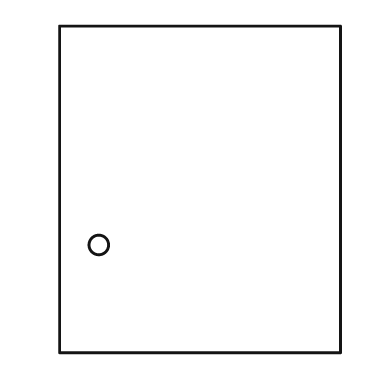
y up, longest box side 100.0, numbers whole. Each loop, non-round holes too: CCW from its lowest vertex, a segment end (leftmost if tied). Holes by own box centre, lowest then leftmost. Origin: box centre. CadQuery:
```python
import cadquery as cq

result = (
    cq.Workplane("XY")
    .moveTo(-43.0, -50.0)
    .lineTo(43.0, -50.0)
    .lineTo(43.0, 50.0)
    .lineTo(-43.0, 50.0)
    .close()
    .moveTo(-31.0, -17.0)
    .circle(3.0)
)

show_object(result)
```